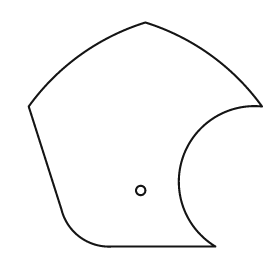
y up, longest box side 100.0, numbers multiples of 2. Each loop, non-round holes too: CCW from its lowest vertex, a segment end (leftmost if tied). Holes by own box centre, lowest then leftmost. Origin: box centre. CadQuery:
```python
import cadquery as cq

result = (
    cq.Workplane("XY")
    .moveTo(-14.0, -48.0)
    .lineTo(30.0, -48.0)
    .threePointArc((16.0, -10.0), (50.0, 12.0))
    .threePointArc((28.0, 34.0), (0.0, 48.0))
    .threePointArc((-28.0, 34.0), (-50.0, 12.0))
    .lineTo(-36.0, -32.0)
    .threePointArc((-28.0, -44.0), (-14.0, -48.0))
    .close()
    .moveTo(-2.0, -24.0)
    .circle(2.0)
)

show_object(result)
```